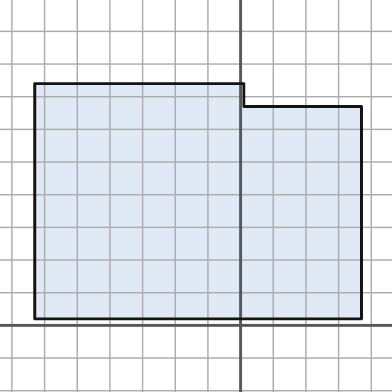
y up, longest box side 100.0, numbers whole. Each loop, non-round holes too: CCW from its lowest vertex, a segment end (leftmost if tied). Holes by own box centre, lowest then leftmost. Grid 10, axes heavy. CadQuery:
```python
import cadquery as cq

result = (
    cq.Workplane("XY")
    .moveTo(-63.0, 2.0)
    .lineTo(37.0, 2.0)
    .lineTo(37.0, 67.0)
    .lineTo(1.0, 67.0)
    .lineTo(1.0, 74.0)
    .lineTo(-63.0, 74.0)
    .close()
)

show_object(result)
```